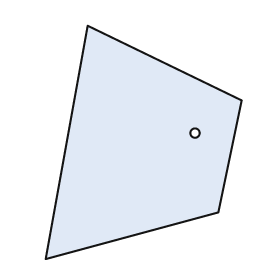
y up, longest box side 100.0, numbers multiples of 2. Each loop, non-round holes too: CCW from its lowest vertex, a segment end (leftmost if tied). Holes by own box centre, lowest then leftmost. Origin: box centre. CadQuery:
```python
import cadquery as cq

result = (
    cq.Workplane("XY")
    .moveTo(-42.0, -50.0)
    .lineTo(32.0, -30.0)
    .lineTo(42.0, 18.0)
    .lineTo(-24.0, 50.0)
    .close()
    .moveTo(22.0, 4.0)
    .circle(2.0)
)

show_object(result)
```